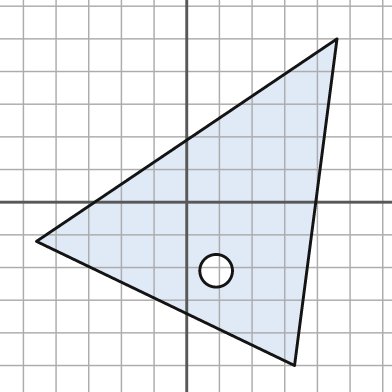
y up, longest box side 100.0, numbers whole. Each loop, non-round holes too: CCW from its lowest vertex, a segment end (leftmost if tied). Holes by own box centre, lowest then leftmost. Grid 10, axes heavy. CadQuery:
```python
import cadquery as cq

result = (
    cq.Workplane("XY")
    .moveTo(33.0, -50.0)
    .lineTo(46.0, 50.0)
    .lineTo(-46.0, -12.0)
    .close()
    .moveTo(9.0, -21.0)
    .circle(5.0)
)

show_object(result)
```